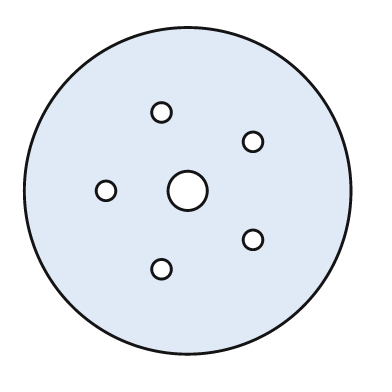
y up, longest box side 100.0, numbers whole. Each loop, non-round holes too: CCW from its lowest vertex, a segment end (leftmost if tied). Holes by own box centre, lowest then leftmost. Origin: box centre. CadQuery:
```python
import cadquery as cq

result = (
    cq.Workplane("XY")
    .moveTo(0.0, 0.0)
    .circle(50.0)
    .moveTo(-8.0, -24.0)
    .circle(3.0)
    .moveTo(20.0, -15.0)
    .circle(3.0)
    .moveTo(-25.0, 0.0)
    .circle(3.0)
    .moveTo(0.0, 0.0)
    .circle(6.0)
    .moveTo(20.0, 15.0)
    .circle(3.0)
    .moveTo(-8.0, 24.0)
    .circle(3.0)
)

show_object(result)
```